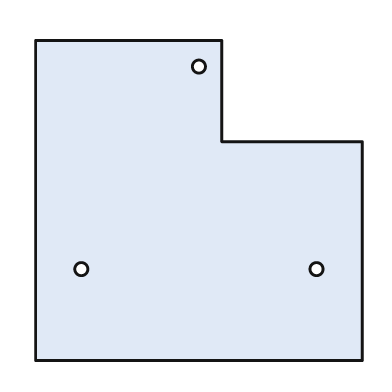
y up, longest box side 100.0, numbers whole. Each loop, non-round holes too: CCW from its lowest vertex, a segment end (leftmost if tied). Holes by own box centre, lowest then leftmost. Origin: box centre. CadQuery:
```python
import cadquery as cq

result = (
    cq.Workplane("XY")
    .moveTo(-50.0, -49.0)
    .lineTo(50.0, -49.0)
    .lineTo(50.0, 18.0)
    .lineTo(7.0, 18.0)
    .lineTo(7.0, 49.0)
    .lineTo(-50.0, 49.0)
    .close()
    .moveTo(-36.0, -21.0)
    .circle(2.0)
    .moveTo(36.0, -21.0)
    .circle(2.0)
    .moveTo(0.0, 41.0)
    .circle(2.0)
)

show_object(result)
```